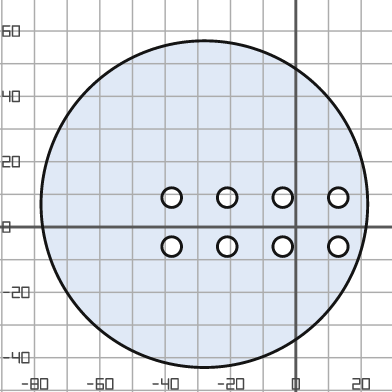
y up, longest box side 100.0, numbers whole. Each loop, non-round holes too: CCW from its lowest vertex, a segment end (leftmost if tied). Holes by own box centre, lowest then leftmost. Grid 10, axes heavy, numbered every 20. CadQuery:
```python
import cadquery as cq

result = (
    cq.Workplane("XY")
    .moveTo(-28.0, 7.0)
    .circle(50.0)
    .moveTo(-38.0, -6.0)
    .circle(3.0)
    .moveTo(-21.0, -6.0)
    .circle(3.0)
    .moveTo(-4.0, -6.0)
    .circle(3.0)
    .moveTo(13.0, -6.0)
    .circle(3.0)
    .moveTo(-38.0, 9.0)
    .circle(3.0)
    .moveTo(-21.0, 9.0)
    .circle(3.0)
    .moveTo(-4.0, 9.0)
    .circle(3.0)
    .moveTo(13.0, 9.0)
    .circle(3.0)
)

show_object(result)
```